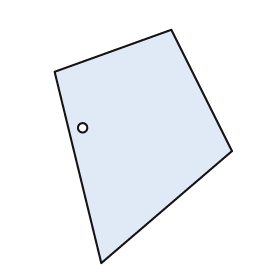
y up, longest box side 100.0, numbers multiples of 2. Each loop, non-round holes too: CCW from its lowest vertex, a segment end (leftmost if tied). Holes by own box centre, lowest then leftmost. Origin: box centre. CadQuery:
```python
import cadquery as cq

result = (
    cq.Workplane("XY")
    .moveTo(-18.0, -50.0)
    .lineTo(38.0, -2.0)
    .lineTo(12.0, 50.0)
    .lineTo(-38.0, 32.0)
    .close()
    .moveTo(-26.0, 8.0)
    .circle(2.0)
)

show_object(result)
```